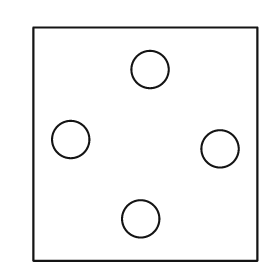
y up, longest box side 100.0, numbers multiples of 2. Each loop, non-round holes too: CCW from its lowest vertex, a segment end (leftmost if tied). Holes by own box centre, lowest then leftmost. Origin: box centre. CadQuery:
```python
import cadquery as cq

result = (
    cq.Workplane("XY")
    .moveTo(-48.0, -50.0)
    .lineTo(48.0, -50.0)
    .lineTo(48.0, 50.0)
    .lineTo(-48.0, 50.0)
    .close()
    .moveTo(-2.0, -32.0)
    .circle(8.0)
    .moveTo(32.0, -2.0)
    .circle(8.0)
    .moveTo(-32.0, 2.0)
    .circle(8.0)
    .moveTo(2.0, 32.0)
    .circle(8.0)
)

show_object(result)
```